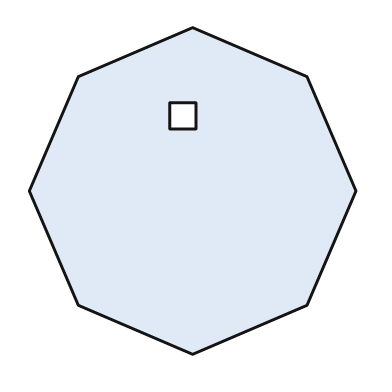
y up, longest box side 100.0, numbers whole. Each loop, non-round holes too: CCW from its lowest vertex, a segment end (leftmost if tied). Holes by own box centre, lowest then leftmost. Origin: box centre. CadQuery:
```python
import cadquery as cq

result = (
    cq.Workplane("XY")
    .moveTo(0.0, -50.0)
    .lineTo(35.0, -35.0)
    .lineTo(50.0, 0.0)
    .lineTo(35.0, 35.0)
    .lineTo(0.0, 50.0)
    .lineTo(-35.0, 35.0)
    .lineTo(-50.0, 0.0)
    .lineTo(-35.0, -35.0)
    .close()
    .moveTo(-7.0, 19.0)
    .lineTo(1.0, 19.0)
    .lineTo(1.0, 27.0)
    .lineTo(-7.0, 27.0)
    .close()
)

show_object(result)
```